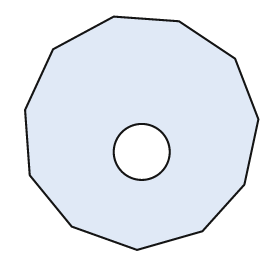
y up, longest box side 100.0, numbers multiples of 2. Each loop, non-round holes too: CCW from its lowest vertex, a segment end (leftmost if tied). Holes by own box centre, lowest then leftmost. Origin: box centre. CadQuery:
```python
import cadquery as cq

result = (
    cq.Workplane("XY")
    .moveTo(-2.0, -50.0)
    .lineTo(26.0, -42.0)
    .lineTo(44.0, -22.0)
    .lineTo(50.0, 6.0)
    .lineTo(40.0, 32.0)
    .lineTo(16.0, 48.0)
    .lineTo(-12.0, 50.0)
    .lineTo(-38.0, 36.0)
    .lineTo(-50.0, 10.0)
    .lineTo(-48.0, -18.0)
    .lineTo(-30.0, -40.0)
    .close()
    .moveTo(0.0, -8.0)
    .circle(12.0)
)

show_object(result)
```